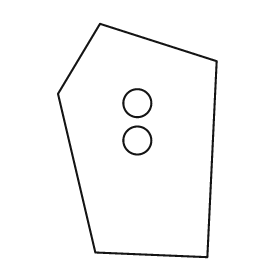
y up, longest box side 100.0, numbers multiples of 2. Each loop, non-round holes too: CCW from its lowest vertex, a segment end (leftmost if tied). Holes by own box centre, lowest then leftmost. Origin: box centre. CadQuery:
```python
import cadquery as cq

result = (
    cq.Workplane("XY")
    .moveTo(30.0, -50.0)
    .lineTo(34.0, 34.0)
    .lineTo(-16.0, 50.0)
    .lineTo(-34.0, 20.0)
    .lineTo(-18.0, -48.0)
    .close()
    .moveTo(0.0, 0.0)
    .circle(6.0)
    .moveTo(0.0, 16.0)
    .circle(6.0)
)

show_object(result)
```